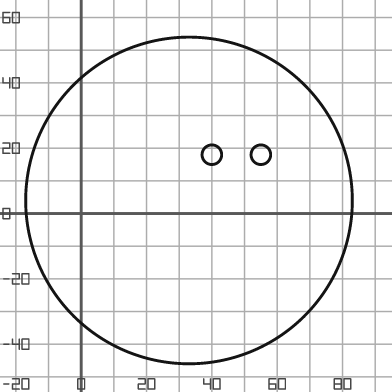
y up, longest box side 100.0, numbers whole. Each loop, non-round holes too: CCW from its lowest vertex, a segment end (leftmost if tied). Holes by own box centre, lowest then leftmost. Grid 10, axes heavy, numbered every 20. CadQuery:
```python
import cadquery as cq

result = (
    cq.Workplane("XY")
    .moveTo(33.0, 4.0)
    .circle(50.0)
    .moveTo(40.0, 18.0)
    .circle(3.0)
    .moveTo(55.0, 18.0)
    .circle(3.0)
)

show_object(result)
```